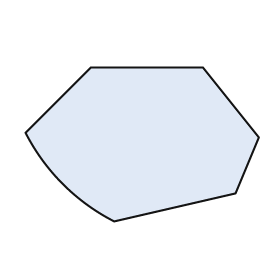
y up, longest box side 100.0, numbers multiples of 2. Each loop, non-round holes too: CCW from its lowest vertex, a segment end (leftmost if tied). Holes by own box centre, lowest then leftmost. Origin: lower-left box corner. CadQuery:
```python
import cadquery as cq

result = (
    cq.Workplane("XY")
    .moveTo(38.0, 0.0)
    .lineTo(90.0, 12.0)
    .lineTo(100.0, 36.0)
    .lineTo(76.0, 66.0)
    .lineTo(28.0, 66.0)
    .lineTo(0.0, 38.0)
    .threePointArc((16.0, 16.0), (38.0, 0.0))
    .close()
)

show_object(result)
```